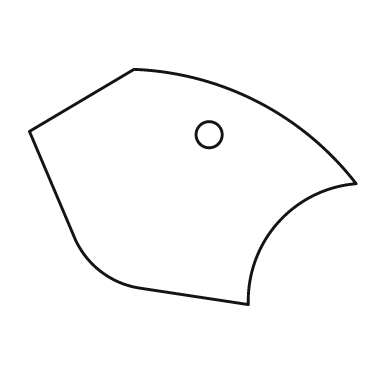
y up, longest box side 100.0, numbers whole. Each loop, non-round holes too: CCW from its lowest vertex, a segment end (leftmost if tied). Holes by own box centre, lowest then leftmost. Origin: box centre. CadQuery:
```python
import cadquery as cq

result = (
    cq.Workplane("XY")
    .moveTo(17.0, -36.0)
    .threePointArc((26.0, -11.0), (50.0, 1.0))
    .threePointArc((20.0, 26.0), (-18.0, 36.0))
    .lineTo(-50.0, 17.0)
    .lineTo(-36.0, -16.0)
    .threePointArc((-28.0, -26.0), (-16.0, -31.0))
    .close()
    .moveTo(5.0, 16.0)
    .circle(4.0)
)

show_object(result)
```